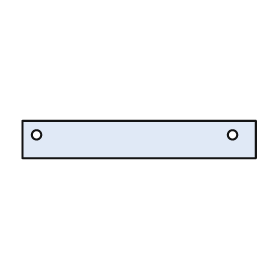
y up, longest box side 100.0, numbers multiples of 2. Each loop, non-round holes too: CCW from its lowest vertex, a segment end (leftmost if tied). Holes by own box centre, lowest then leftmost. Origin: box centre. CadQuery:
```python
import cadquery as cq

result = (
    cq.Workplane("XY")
    .moveTo(-50.0, -8.0)
    .lineTo(50.0, -8.0)
    .lineTo(50.0, 8.0)
    .lineTo(-50.0, 8.0)
    .close()
    .moveTo(-44.0, 2.0)
    .circle(2.0)
    .moveTo(40.0, 2.0)
    .circle(2.0)
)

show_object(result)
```